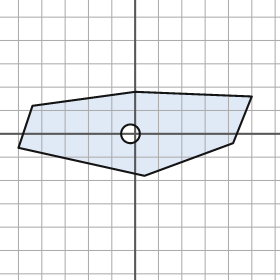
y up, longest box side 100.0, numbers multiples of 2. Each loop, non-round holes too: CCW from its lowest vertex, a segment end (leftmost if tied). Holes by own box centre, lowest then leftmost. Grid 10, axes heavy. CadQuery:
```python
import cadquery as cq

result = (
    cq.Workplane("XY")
    .moveTo(4.0, -18.0)
    .lineTo(42.0, -4.0)
    .lineTo(50.0, 16.0)
    .lineTo(0.0, 18.0)
    .lineTo(-44.0, 12.0)
    .lineTo(-50.0, -6.0)
    .close()
    .moveTo(-2.0, 0.0)
    .circle(4.0)
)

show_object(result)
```